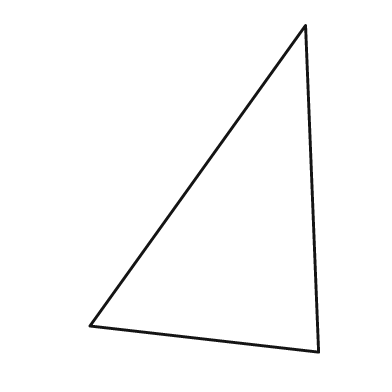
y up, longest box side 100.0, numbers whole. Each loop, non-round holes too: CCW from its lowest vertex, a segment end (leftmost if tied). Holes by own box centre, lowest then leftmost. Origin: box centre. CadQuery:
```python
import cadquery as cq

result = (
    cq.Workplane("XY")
    .moveTo(35.0, -50.0)
    .lineTo(31.0, 50.0)
    .lineTo(-35.0, -42.0)
    .close()
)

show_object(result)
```